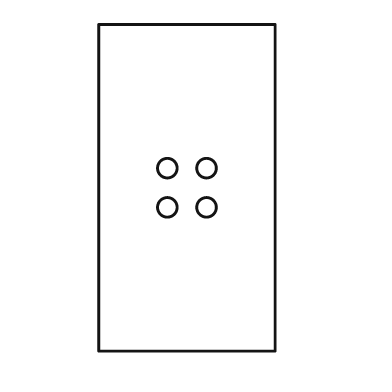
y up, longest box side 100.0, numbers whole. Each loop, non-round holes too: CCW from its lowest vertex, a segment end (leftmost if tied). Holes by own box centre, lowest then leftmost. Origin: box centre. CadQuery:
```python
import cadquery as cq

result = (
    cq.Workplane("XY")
    .moveTo(-27.0, -50.0)
    .lineTo(27.0, -50.0)
    .lineTo(27.0, 50.0)
    .lineTo(-27.0, 50.0)
    .close()
    .moveTo(-6.0, -6.0)
    .circle(3.0)
    .moveTo(6.0, -6.0)
    .circle(3.0)
    .moveTo(-6.0, 6.0)
    .circle(3.0)
    .moveTo(6.0, 6.0)
    .circle(3.0)
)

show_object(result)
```